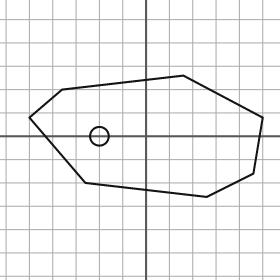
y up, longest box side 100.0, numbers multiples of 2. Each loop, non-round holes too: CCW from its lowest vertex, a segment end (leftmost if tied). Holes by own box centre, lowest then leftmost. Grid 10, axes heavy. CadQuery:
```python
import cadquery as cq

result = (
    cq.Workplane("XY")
    .moveTo(26.0, -26.0)
    .lineTo(46.0, -16.0)
    .lineTo(50.0, 8.0)
    .lineTo(16.0, 26.0)
    .lineTo(-36.0, 20.0)
    .lineTo(-50.0, 8.0)
    .lineTo(-26.0, -20.0)
    .close()
    .moveTo(-20.0, 0.0)
    .circle(4.0)
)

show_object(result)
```